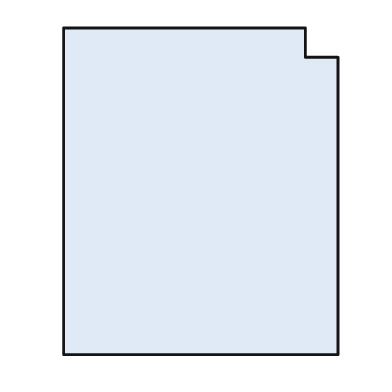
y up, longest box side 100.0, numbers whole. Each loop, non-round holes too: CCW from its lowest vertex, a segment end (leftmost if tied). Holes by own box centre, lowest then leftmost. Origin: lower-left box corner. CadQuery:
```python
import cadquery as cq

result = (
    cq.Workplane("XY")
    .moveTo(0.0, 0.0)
    .lineTo(84.0, 0.0)
    .lineTo(84.0, 91.0)
    .lineTo(74.0, 91.0)
    .lineTo(74.0, 100.0)
    .lineTo(0.0, 100.0)
    .close()
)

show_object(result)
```